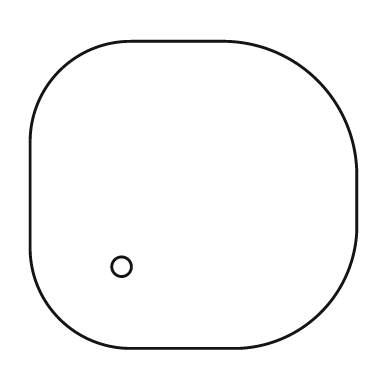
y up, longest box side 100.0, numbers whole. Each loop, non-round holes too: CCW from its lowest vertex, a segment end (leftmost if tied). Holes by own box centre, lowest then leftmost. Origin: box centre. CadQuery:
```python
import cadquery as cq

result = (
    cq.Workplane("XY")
    .moveTo(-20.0, -47.0)
    .lineTo(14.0, -47.0)
    .threePointArc((39.0, -36.0), (50.0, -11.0))
    .lineTo(50.0, 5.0)
    .threePointArc((38.0, 35.0), (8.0, 47.0))
    .lineTo(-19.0, 47.0)
    .threePointArc((-41.0, 38.0), (-50.0, 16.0))
    .lineTo(-50.0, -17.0)
    .threePointArc((-41.0, -38.0), (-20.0, -47.0))
    .close()
    .moveTo(-22.0, -22.0)
    .circle(3.0)
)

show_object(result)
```